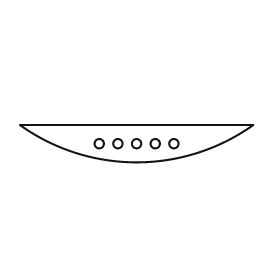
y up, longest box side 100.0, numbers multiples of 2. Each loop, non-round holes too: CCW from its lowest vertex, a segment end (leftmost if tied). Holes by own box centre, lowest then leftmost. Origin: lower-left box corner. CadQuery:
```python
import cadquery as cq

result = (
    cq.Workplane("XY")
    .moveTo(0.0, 16.0)
    .threePointArc((50.0, 0.0), (100.0, 16.0))
    .close()
    .moveTo(34.0, 8.0)
    .circle(2.0)
    .moveTo(42.0, 8.0)
    .circle(2.0)
    .moveTo(50.0, 8.0)
    .circle(2.0)
    .moveTo(58.0, 8.0)
    .circle(2.0)
    .moveTo(66.0, 8.0)
    .circle(2.0)
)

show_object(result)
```